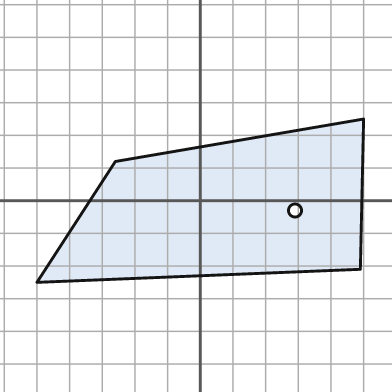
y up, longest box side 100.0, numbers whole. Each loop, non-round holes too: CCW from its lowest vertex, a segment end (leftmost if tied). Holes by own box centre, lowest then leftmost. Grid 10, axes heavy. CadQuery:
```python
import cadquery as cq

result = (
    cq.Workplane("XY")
    .moveTo(-50.0, -25.0)
    .lineTo(49.0, -21.0)
    .lineTo(50.0, 25.0)
    .lineTo(-26.0, 12.0)
    .close()
    .moveTo(29.0, -3.0)
    .circle(2.0)
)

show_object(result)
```